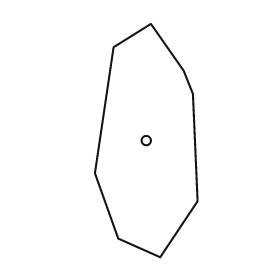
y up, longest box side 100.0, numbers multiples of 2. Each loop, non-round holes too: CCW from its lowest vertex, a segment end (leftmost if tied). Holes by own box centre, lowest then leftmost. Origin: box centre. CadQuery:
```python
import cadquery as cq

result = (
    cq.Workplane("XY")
    .moveTo(6.0, -50.0)
    .lineTo(22.0, -26.0)
    .lineTo(20.0, 20.0)
    .lineTo(16.0, 30.0)
    .lineTo(2.0, 50.0)
    .lineTo(-14.0, 40.0)
    .lineTo(-22.0, -14.0)
    .lineTo(-12.0, -42.0)
    .close()
    .moveTo(0.0, 0.0)
    .circle(2.0)
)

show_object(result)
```